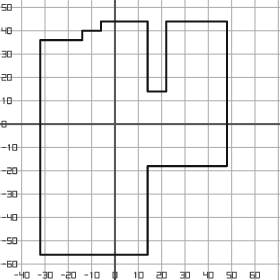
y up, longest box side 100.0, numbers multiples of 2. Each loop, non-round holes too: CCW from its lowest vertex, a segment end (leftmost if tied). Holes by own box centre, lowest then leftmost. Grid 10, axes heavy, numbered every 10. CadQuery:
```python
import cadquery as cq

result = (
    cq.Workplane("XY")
    .moveTo(-32.0, -56.0)
    .lineTo(14.0, -56.0)
    .lineTo(14.0, -18.0)
    .lineTo(48.0, -18.0)
    .lineTo(48.0, 44.0)
    .lineTo(22.0, 44.0)
    .lineTo(22.0, 14.0)
    .lineTo(14.0, 14.0)
    .lineTo(14.0, 44.0)
    .lineTo(-6.0, 44.0)
    .lineTo(-6.0, 40.0)
    .lineTo(-14.0, 40.0)
    .lineTo(-14.0, 36.0)
    .lineTo(-32.0, 36.0)
    .close()
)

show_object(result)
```